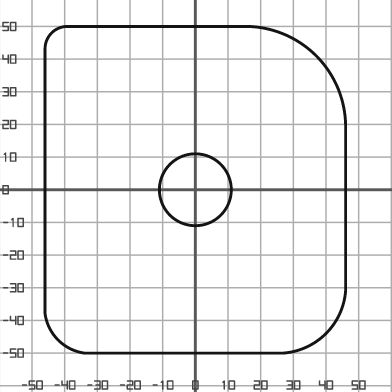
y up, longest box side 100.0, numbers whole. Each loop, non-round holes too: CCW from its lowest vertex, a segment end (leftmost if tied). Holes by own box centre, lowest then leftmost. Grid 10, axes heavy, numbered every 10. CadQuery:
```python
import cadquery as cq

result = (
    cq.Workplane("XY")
    .moveTo(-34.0, -50.0)
    .lineTo(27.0, -50.0)
    .threePointArc((40.0, -44.0), (46.0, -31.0))
    .lineTo(46.0, 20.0)
    .threePointArc((37.0, 41.0), (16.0, 50.0))
    .lineTo(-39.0, 50.0)
    .threePointArc((-44.0, 48.0), (-46.0, 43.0))
    .lineTo(-46.0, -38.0)
    .threePointArc((-42.0, -46.0), (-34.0, -50.0))
    .close()
    .moveTo(0.0, 0.0)
    .circle(11.0)
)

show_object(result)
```